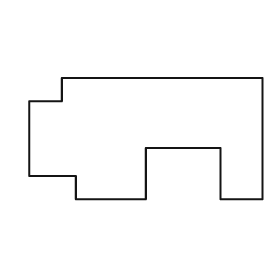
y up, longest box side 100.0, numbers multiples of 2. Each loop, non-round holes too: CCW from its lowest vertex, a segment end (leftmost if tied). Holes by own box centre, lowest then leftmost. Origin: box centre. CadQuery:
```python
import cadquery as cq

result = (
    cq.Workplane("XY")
    .moveTo(-30.0, -26.0)
    .lineTo(0.0, -26.0)
    .lineTo(0.0, -4.0)
    .lineTo(32.0, -4.0)
    .lineTo(32.0, -26.0)
    .lineTo(50.0, -26.0)
    .lineTo(50.0, 26.0)
    .lineTo(-36.0, 26.0)
    .lineTo(-36.0, 16.0)
    .lineTo(-50.0, 16.0)
    .lineTo(-50.0, -16.0)
    .lineTo(-30.0, -16.0)
    .close()
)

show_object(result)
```